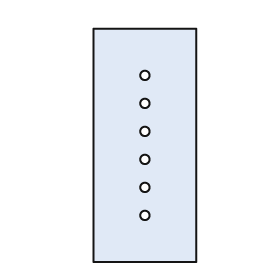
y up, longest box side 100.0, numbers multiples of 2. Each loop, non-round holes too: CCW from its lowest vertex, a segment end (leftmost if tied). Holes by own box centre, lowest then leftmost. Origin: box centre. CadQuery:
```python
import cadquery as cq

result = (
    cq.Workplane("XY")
    .moveTo(-22.0, -50.0)
    .lineTo(22.0, -50.0)
    .lineTo(22.0, 50.0)
    .lineTo(-22.0, 50.0)
    .close()
    .moveTo(0.0, -30.0)
    .circle(2.0)
    .moveTo(0.0, -18.0)
    .circle(2.0)
    .moveTo(0.0, -6.0)
    .circle(2.0)
    .moveTo(0.0, 6.0)
    .circle(2.0)
    .moveTo(0.0, 18.0)
    .circle(2.0)
    .moveTo(0.0, 30.0)
    .circle(2.0)
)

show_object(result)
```